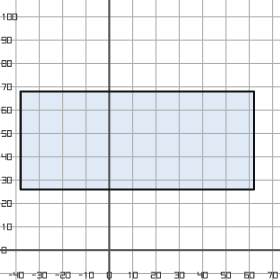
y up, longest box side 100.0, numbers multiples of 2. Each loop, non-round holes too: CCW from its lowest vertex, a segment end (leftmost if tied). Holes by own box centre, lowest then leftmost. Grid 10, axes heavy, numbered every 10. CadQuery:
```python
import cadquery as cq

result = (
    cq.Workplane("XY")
    .moveTo(-38.0, 26.0)
    .lineTo(62.0, 26.0)
    .lineTo(62.0, 68.0)
    .lineTo(-38.0, 68.0)
    .close()
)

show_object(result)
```